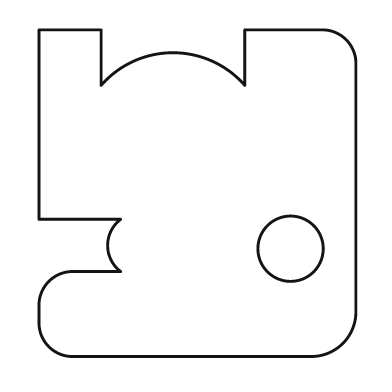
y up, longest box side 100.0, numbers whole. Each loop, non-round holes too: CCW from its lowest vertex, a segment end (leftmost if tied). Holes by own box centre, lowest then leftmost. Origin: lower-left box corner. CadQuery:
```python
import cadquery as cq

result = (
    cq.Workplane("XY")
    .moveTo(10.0, 0.0)
    .lineTo(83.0, 0.0)
    .threePointArc((93.0, 4.0), (97.0, 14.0))
    .lineTo(97.0, 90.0)
    .threePointArc((94.0, 97.0), (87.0, 100.0))
    .lineTo(63.0, 100.0)
    .lineTo(63.0, 83.0)
    .threePointArc((41.0, 93.0), (19.0, 83.0))
    .lineTo(19.0, 100.0)
    .lineTo(0.0, 100.0)
    .lineTo(0.0, 42.0)
    .lineTo(25.0, 42.0)
    .threePointArc((21.0, 34.0), (25.0, 26.0))
    .lineTo(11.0, 26.0)
    .threePointArc((3.0, 23.0), (0.0, 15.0))
    .lineTo(0.0, 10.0)
    .threePointArc((3.0, 3.0), (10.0, 0.0))
    .close()
    .moveTo(77.0, 33.0)
    .circle(10.0)
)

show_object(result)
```